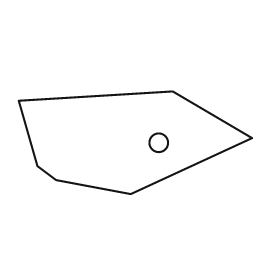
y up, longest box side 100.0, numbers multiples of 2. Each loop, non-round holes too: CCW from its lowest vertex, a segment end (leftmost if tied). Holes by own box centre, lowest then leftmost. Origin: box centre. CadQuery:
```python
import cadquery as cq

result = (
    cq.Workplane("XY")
    .moveTo(-2.0, -22.0)
    .lineTo(50.0, 2.0)
    .lineTo(16.0, 22.0)
    .lineTo(-50.0, 18.0)
    .lineTo(-42.0, -10.0)
    .lineTo(-34.0, -16.0)
    .close()
    .moveTo(10.0, 0.0)
    .circle(4.0)
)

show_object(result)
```